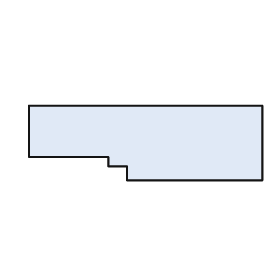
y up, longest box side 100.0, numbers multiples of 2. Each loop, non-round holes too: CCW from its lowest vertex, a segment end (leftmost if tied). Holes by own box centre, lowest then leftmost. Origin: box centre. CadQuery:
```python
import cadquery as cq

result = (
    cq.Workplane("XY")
    .moveTo(-8.0, -16.0)
    .lineTo(50.0, -16.0)
    .lineTo(50.0, 16.0)
    .lineTo(-50.0, 16.0)
    .lineTo(-50.0, -6.0)
    .lineTo(-16.0, -6.0)
    .lineTo(-16.0, -10.0)
    .lineTo(-8.0, -10.0)
    .close()
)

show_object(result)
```